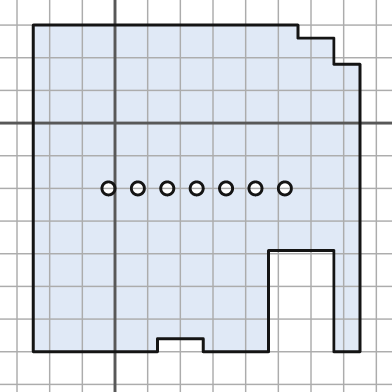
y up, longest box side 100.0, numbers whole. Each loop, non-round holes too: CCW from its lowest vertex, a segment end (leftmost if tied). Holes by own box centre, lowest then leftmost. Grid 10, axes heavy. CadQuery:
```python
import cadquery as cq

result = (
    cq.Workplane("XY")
    .moveTo(-25.0, -70.0)
    .lineTo(13.0, -70.0)
    .lineTo(13.0, -66.0)
    .lineTo(27.0, -66.0)
    .lineTo(27.0, -70.0)
    .lineTo(47.0, -70.0)
    .lineTo(47.0, -39.0)
    .lineTo(67.0, -39.0)
    .lineTo(67.0, -70.0)
    .lineTo(75.0, -70.0)
    .lineTo(75.0, 18.0)
    .lineTo(67.0, 18.0)
    .lineTo(67.0, 26.0)
    .lineTo(56.0, 26.0)
    .lineTo(56.0, 30.0)
    .lineTo(-25.0, 30.0)
    .close()
    .moveTo(-2.0, -20.0)
    .circle(2.0)
    .moveTo(7.0, -20.0)
    .circle(2.0)
    .moveTo(16.0, -20.0)
    .circle(2.0)
    .moveTo(25.0, -20.0)
    .circle(2.0)
    .moveTo(34.0, -20.0)
    .circle(2.0)
    .moveTo(43.0, -20.0)
    .circle(2.0)
    .moveTo(52.0, -20.0)
    .circle(2.0)
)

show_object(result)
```